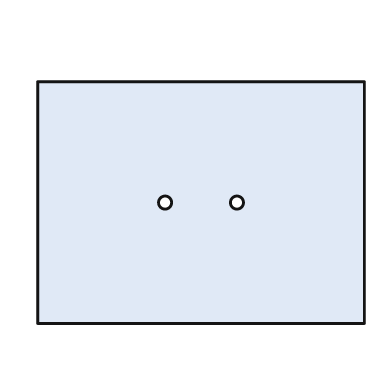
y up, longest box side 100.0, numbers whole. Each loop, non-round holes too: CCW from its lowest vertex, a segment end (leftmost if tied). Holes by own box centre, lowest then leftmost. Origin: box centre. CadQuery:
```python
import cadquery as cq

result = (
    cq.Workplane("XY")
    .moveTo(-50.0, -37.0)
    .lineTo(50.0, -37.0)
    .lineTo(50.0, 37.0)
    .lineTo(-50.0, 37.0)
    .close()
    .moveTo(-11.0, 0.0)
    .circle(2.0)
    .moveTo(11.0, 0.0)
    .circle(2.0)
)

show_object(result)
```